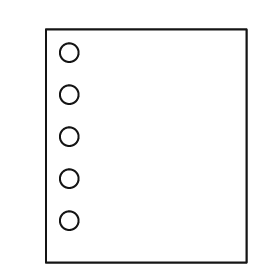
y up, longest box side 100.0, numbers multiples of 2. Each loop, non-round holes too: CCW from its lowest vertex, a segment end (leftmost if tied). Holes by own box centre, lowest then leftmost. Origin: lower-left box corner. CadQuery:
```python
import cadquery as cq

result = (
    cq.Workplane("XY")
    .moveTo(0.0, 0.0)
    .lineTo(86.0, 0.0)
    .lineTo(86.0, 100.0)
    .lineTo(0.0, 100.0)
    .close()
    .moveTo(10.0, 18.0)
    .circle(4.0)
    .moveTo(10.0, 36.0)
    .circle(4.0)
    .moveTo(10.0, 54.0)
    .circle(4.0)
    .moveTo(10.0, 72.0)
    .circle(4.0)
    .moveTo(10.0, 90.0)
    .circle(4.0)
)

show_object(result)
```